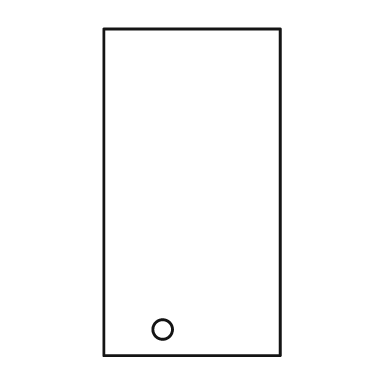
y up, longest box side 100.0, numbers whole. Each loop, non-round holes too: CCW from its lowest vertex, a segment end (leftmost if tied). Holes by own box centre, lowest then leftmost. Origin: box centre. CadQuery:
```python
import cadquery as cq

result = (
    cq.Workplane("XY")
    .moveTo(-27.0, -50.0)
    .lineTo(27.0, -50.0)
    .lineTo(27.0, 50.0)
    .lineTo(-27.0, 50.0)
    .close()
    .moveTo(-9.0, -42.0)
    .circle(3.0)
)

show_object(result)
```